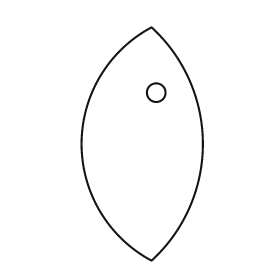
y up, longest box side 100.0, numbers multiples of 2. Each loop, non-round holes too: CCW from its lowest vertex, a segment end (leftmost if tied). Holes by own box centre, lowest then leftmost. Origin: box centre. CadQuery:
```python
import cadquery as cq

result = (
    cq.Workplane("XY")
    .moveTo(4.0, -50.0)
    .threePointArc((26.0, 0.0), (4.0, 50.0))
    .threePointArc((-26.0, 0.0), (4.0, -50.0))
    .close()
    .moveTo(6.0, 22.0)
    .circle(4.0)
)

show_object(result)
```